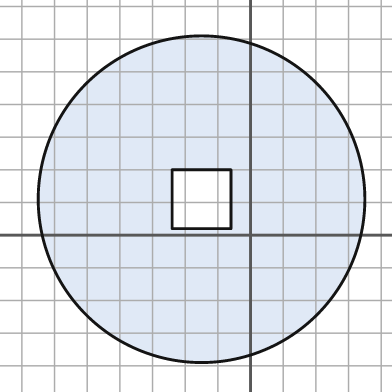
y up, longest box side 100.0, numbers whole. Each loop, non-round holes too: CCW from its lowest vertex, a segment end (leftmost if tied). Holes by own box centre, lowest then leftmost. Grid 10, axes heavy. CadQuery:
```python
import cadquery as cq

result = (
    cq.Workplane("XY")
    .moveTo(-15.0, 11.0)
    .circle(50.0)
    .moveTo(-24.0, 2.0)
    .lineTo(-6.0, 2.0)
    .lineTo(-6.0, 20.0)
    .lineTo(-24.0, 20.0)
    .close()
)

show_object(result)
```